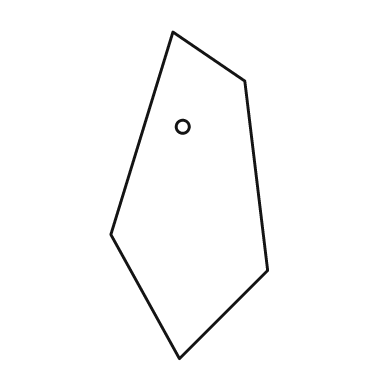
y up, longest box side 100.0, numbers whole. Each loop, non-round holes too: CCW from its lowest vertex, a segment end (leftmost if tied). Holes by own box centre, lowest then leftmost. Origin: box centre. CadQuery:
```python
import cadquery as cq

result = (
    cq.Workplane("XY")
    .moveTo(-3.0, -50.0)
    .lineTo(24.0, -23.0)
    .lineTo(17.0, 35.0)
    .lineTo(-5.0, 50.0)
    .lineTo(-24.0, -12.0)
    .close()
    .moveTo(-2.0, 21.0)
    .circle(2.0)
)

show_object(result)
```